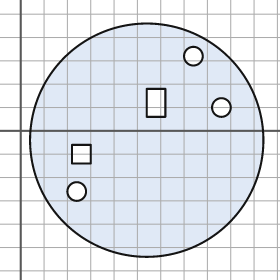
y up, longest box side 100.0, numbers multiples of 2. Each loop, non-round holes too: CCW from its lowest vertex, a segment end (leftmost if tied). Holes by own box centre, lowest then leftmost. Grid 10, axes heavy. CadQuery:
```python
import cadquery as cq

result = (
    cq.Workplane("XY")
    .moveTo(54.0, -4.0)
    .circle(50.0)
    .moveTo(24.0, -26.0)
    .circle(4.0)
    .moveTo(22.0, -14.0)
    .lineTo(30.0, -14.0)
    .lineTo(30.0, -6.0)
    .lineTo(22.0, -6.0)
    .close()
    .moveTo(86.0, 10.0)
    .circle(4.0)
    .moveTo(54.0, 6.0)
    .lineTo(62.0, 6.0)
    .lineTo(62.0, 18.0)
    .lineTo(54.0, 18.0)
    .close()
    .moveTo(74.0, 32.0)
    .circle(4.0)
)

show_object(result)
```